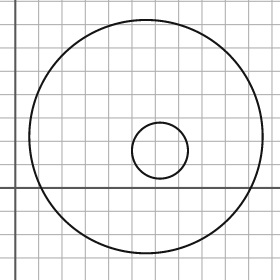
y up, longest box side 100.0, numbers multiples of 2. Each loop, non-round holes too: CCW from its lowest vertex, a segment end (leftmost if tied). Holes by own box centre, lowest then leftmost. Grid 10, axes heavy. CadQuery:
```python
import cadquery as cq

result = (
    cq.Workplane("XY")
    .moveTo(56.0, 22.0)
    .circle(50.0)
    .moveTo(62.0, 16.0)
    .circle(12.0)
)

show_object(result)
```